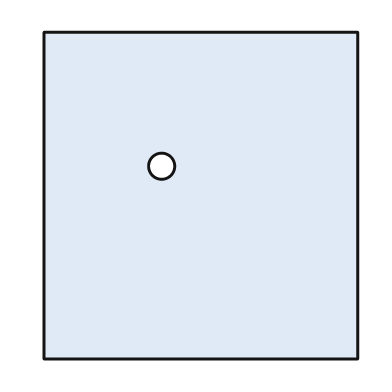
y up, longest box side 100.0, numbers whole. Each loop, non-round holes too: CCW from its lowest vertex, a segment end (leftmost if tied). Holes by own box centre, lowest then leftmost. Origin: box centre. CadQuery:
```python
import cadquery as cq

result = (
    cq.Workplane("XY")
    .moveTo(-48.0, -50.0)
    .lineTo(48.0, -50.0)
    .lineTo(48.0, 50.0)
    .lineTo(-48.0, 50.0)
    .close()
    .moveTo(-12.0, 9.0)
    .circle(4.0)
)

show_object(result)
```